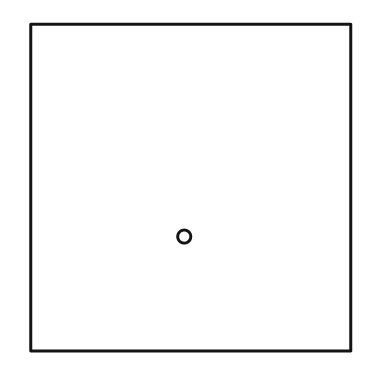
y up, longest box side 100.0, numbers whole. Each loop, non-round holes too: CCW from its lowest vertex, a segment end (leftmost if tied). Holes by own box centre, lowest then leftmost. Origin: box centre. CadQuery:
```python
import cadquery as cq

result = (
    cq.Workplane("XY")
    .moveTo(-49.0, -50.0)
    .lineTo(49.0, -50.0)
    .lineTo(49.0, 50.0)
    .lineTo(-49.0, 50.0)
    .close()
    .moveTo(-2.0, -15.0)
    .circle(2.0)
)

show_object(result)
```